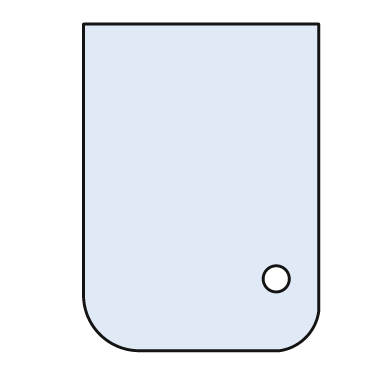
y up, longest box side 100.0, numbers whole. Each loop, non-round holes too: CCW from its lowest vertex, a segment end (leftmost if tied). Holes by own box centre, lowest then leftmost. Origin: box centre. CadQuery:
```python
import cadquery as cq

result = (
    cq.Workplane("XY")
    .moveTo(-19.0, -50.0)
    .lineTo(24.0, -50.0)
    .threePointArc((32.0, -46.0), (36.0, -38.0))
    .lineTo(36.0, 50.0)
    .lineTo(-36.0, 50.0)
    .lineTo(-36.0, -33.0)
    .threePointArc((-31.0, -45.0), (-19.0, -50.0))
    .close()
    .moveTo(23.0, -28.0)
    .circle(4.0)
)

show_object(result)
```